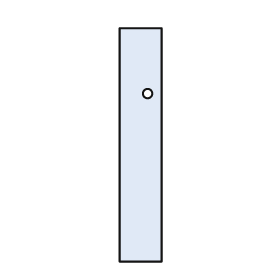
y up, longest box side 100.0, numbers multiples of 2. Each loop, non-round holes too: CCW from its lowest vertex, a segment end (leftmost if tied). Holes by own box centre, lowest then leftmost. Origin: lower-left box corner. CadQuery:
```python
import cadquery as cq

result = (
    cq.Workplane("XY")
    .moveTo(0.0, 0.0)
    .lineTo(18.0, 0.0)
    .lineTo(18.0, 100.0)
    .lineTo(0.0, 100.0)
    .close()
    .moveTo(12.0, 72.0)
    .circle(2.0)
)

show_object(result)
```